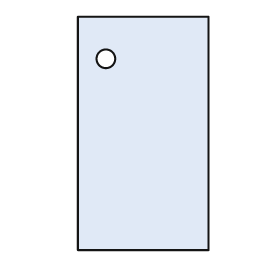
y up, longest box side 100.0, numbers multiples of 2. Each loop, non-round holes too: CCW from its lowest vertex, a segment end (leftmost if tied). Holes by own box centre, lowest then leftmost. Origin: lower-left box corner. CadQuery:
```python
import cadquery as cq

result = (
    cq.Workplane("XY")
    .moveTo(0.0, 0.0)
    .lineTo(56.0, 0.0)
    .lineTo(56.0, 100.0)
    .lineTo(0.0, 100.0)
    .close()
    .moveTo(12.0, 82.0)
    .circle(4.0)
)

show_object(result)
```